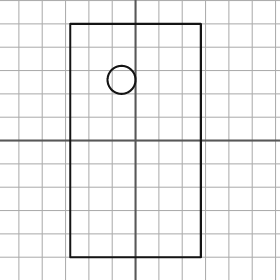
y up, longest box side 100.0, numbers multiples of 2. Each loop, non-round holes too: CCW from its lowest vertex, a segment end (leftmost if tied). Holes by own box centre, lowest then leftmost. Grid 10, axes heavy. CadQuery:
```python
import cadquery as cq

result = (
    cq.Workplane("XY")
    .moveTo(-28.0, -50.0)
    .lineTo(28.0, -50.0)
    .lineTo(28.0, 50.0)
    .lineTo(-28.0, 50.0)
    .close()
    .moveTo(-6.0, 26.0)
    .circle(6.0)
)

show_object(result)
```